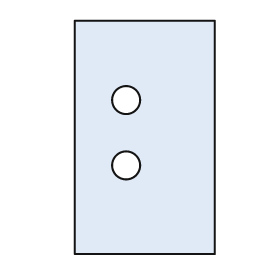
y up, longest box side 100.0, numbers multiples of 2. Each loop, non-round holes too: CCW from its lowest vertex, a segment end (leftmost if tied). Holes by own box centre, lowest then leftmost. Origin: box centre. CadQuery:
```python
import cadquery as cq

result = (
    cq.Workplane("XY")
    .moveTo(-30.0, -50.0)
    .lineTo(30.0, -50.0)
    .lineTo(30.0, 50.0)
    .lineTo(-30.0, 50.0)
    .close()
    .moveTo(-8.0, -12.0)
    .circle(6.0)
    .moveTo(-8.0, 16.0)
    .circle(6.0)
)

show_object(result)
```